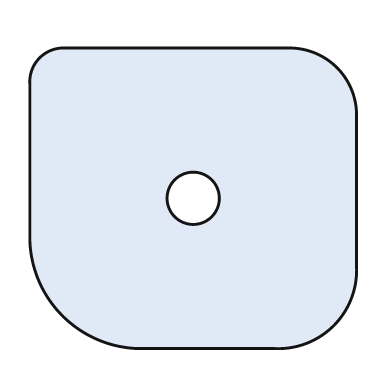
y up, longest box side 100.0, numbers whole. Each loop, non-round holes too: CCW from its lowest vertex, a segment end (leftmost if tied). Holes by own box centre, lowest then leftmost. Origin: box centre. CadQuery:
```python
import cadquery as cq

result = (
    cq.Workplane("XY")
    .moveTo(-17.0, -46.0)
    .lineTo(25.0, -46.0)
    .threePointArc((43.0, -39.0), (50.0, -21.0))
    .lineTo(50.0, 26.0)
    .threePointArc((44.0, 40.0), (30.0, 46.0))
    .lineTo(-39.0, 46.0)
    .threePointArc((-47.0, 43.0), (-50.0, 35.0))
    .lineTo(-50.0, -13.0)
    .threePointArc((-40.0, -36.0), (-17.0, -46.0))
    .close()
    .moveTo(0.0, 0.0)
    .circle(8.0)
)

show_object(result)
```